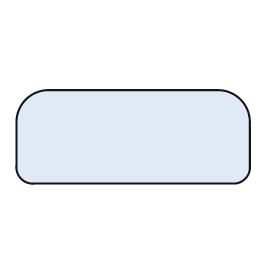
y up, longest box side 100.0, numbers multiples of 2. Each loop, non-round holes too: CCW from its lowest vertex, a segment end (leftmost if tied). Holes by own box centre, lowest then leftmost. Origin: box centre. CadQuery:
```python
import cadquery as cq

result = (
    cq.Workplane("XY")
    .moveTo(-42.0, -20.0)
    .lineTo(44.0, -20.0)
    .threePointArc((48.0, -18.0), (50.0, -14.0))
    .lineTo(50.0, 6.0)
    .threePointArc((46.0, 16.0), (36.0, 20.0))
    .lineTo(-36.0, 20.0)
    .threePointArc((-46.0, 16.0), (-50.0, 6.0))
    .lineTo(-50.0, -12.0)
    .threePointArc((-48.0, -18.0), (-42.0, -20.0))
    .close()
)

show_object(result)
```